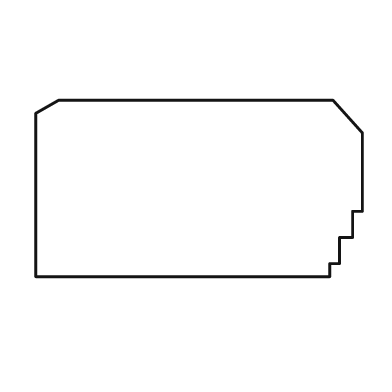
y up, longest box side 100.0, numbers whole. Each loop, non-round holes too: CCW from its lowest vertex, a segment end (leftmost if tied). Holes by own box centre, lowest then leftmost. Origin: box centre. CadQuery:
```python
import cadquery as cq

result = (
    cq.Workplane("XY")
    .moveTo(-50.0, -27.0)
    .lineTo(40.0, -27.0)
    .lineTo(40.0, -23.0)
    .lineTo(43.0, -23.0)
    .lineTo(43.0, -15.0)
    .lineTo(47.0, -15.0)
    .lineTo(47.0, -7.0)
    .lineTo(50.0, -7.0)
    .lineTo(50.0, 17.0)
    .lineTo(41.0, 27.0)
    .lineTo(-43.0, 27.0)
    .lineTo(-50.0, 23.0)
    .close()
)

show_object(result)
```